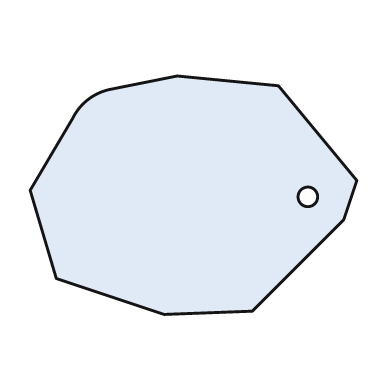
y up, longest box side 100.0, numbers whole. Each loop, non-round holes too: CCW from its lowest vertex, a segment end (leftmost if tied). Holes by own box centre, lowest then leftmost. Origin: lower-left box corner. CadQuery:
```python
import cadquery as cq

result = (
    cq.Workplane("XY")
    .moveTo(41.0, 0.0)
    .lineTo(68.0, 1.0)
    .lineTo(96.0, 29.0)
    .lineTo(100.0, 41.0)
    .lineTo(76.0, 70.0)
    .lineTo(45.0, 73.0)
    .lineTo(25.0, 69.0)
    .threePointArc((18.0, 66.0), (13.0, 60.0))
    .lineTo(0.0, 38.0)
    .lineTo(8.0, 11.0)
    .close()
    .moveTo(85.0, 36.0)
    .circle(3.0)
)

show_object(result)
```